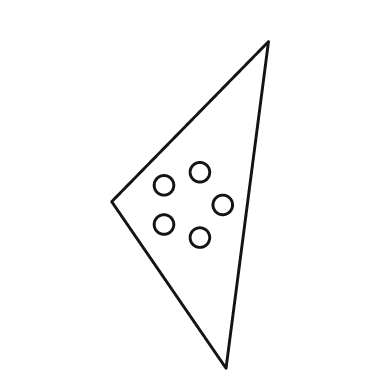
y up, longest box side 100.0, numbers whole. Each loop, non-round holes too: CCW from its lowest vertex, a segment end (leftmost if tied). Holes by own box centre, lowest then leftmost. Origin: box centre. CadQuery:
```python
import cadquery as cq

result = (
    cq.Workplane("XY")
    .moveTo(11.0, -50.0)
    .lineTo(24.0, 50.0)
    .lineTo(-24.0, 1.0)
    .close()
    .moveTo(3.0, -10.0)
    .circle(3.0)
    .moveTo(-8.0, -6.0)
    .circle(3.0)
    .moveTo(10.0, 0.0)
    .circle(3.0)
    .moveTo(-8.0, 6.0)
    .circle(3.0)
    .moveTo(3.0, 10.0)
    .circle(3.0)
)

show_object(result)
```